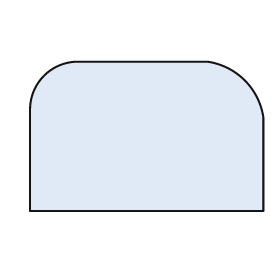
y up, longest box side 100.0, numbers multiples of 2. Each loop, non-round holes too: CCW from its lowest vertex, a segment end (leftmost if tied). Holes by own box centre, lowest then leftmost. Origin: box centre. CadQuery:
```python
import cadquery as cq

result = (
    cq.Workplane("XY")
    .moveTo(-50.0, -32.0)
    .lineTo(50.0, -32.0)
    .lineTo(50.0, 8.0)
    .threePointArc((42.0, 24.0), (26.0, 32.0))
    .lineTo(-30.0, 32.0)
    .threePointArc((-44.0, 26.0), (-50.0, 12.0))
    .close()
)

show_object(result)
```